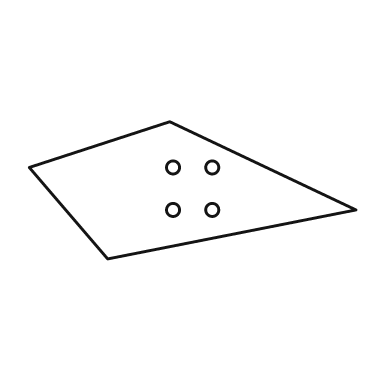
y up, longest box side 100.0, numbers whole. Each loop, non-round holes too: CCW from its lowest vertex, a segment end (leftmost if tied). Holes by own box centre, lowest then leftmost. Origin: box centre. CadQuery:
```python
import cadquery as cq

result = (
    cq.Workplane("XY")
    .moveTo(-26.0, -21.0)
    .lineTo(50.0, -6.0)
    .lineTo(-7.0, 21.0)
    .lineTo(-50.0, 7.0)
    .close()
    .moveTo(-6.0, -6.0)
    .circle(2.0)
    .moveTo(6.0, -6.0)
    .circle(2.0)
    .moveTo(-6.0, 7.0)
    .circle(2.0)
    .moveTo(6.0, 7.0)
    .circle(2.0)
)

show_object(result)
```